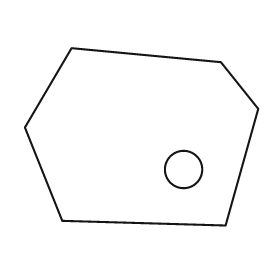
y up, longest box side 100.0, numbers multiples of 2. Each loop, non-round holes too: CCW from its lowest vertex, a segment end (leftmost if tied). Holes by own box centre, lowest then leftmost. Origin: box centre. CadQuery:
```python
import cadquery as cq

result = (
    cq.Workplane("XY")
    .moveTo(36.0, -38.0)
    .lineTo(50.0, 12.0)
    .lineTo(34.0, 32.0)
    .lineTo(-30.0, 38.0)
    .lineTo(-50.0, 4.0)
    .lineTo(-34.0, -36.0)
    .close()
    .moveTo(18.0, -14.0)
    .circle(8.0)
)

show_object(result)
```